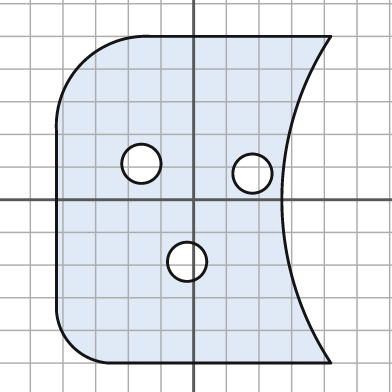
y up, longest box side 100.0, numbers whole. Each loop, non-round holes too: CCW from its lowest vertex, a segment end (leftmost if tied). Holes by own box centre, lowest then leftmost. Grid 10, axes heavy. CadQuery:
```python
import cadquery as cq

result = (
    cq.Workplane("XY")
    .moveTo(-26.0, -50.0)
    .lineTo(42.0, -50.0)
    .threePointArc((27.0, 0.0), (42.0, 50.0))
    .lineTo(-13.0, 50.0)
    .threePointArc((-34.0, 42.0), (-42.0, 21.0))
    .lineTo(-42.0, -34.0)
    .threePointArc((-37.0, -45.0), (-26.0, -50.0))
    .close()
    .moveTo(-2.0, -19.0)
    .circle(6.0)
    .moveTo(18.0, 8.0)
    .circle(6.0)
    .moveTo(-16.0, 11.0)
    .circle(6.0)
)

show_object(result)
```